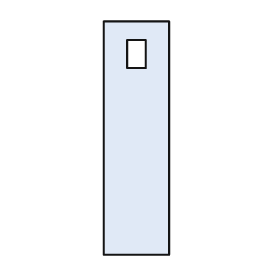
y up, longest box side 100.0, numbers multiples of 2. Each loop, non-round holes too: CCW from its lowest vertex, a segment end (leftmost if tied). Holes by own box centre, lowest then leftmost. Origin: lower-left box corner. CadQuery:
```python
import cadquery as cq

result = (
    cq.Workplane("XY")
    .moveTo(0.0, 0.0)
    .lineTo(28.0, 0.0)
    .lineTo(28.0, 100.0)
    .lineTo(0.0, 100.0)
    .close()
    .moveTo(10.0, 80.0)
    .lineTo(18.0, 80.0)
    .lineTo(18.0, 92.0)
    .lineTo(10.0, 92.0)
    .close()
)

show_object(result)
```